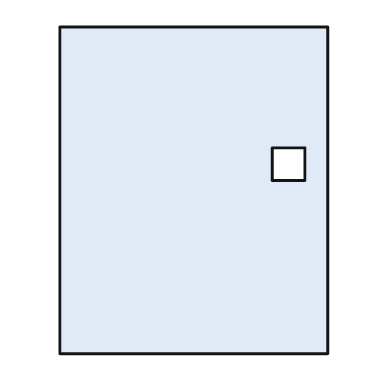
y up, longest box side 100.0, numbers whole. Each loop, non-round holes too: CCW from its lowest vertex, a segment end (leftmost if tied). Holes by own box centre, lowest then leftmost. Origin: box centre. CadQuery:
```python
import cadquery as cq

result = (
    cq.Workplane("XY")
    .moveTo(-41.0, -50.0)
    .lineTo(41.0, -50.0)
    .lineTo(41.0, 50.0)
    .lineTo(-41.0, 50.0)
    .close()
    .moveTo(24.0, 3.0)
    .lineTo(34.0, 3.0)
    .lineTo(34.0, 13.0)
    .lineTo(24.0, 13.0)
    .close()
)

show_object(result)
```